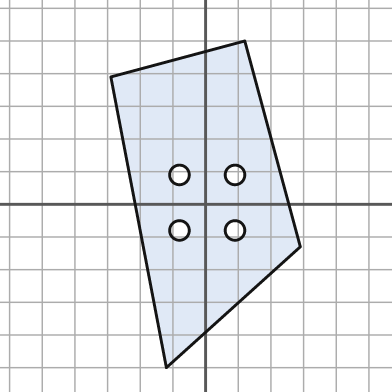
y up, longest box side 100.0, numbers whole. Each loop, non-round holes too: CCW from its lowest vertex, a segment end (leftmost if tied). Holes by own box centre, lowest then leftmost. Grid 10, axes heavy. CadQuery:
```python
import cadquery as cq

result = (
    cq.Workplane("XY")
    .moveTo(-12.0, -50.0)
    .lineTo(29.0, -13.0)
    .lineTo(12.0, 50.0)
    .lineTo(-29.0, 39.0)
    .close()
    .moveTo(-8.0, -8.0)
    .circle(3.0)
    .moveTo(9.0, -8.0)
    .circle(3.0)
    .moveTo(-8.0, 9.0)
    .circle(3.0)
    .moveTo(9.0, 9.0)
    .circle(3.0)
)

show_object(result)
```